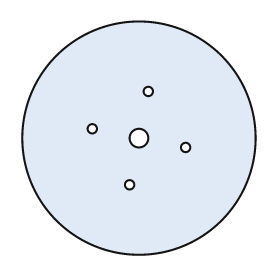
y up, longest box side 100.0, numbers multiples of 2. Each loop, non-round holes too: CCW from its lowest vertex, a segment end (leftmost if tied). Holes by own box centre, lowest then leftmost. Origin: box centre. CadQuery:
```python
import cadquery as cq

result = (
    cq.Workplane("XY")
    .moveTo(0.0, 0.0)
    .circle(50.0)
    .moveTo(-4.0, -20.0)
    .circle(2.0)
    .moveTo(20.0, -4.0)
    .circle(2.0)
    .moveTo(0.0, 0.0)
    .circle(4.0)
    .moveTo(-20.0, 4.0)
    .circle(2.0)
    .moveTo(4.0, 20.0)
    .circle(2.0)
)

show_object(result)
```